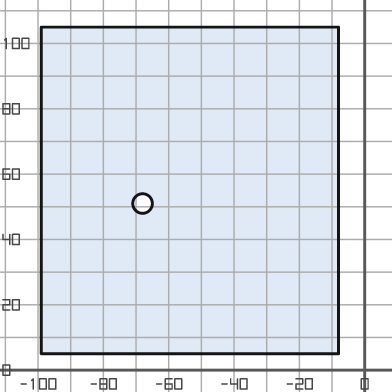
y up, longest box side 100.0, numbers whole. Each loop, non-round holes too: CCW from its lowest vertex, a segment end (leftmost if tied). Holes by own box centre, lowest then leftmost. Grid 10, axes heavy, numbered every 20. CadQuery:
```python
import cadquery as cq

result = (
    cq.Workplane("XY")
    .moveTo(-99.0, 5.0)
    .lineTo(-8.0, 5.0)
    .lineTo(-8.0, 105.0)
    .lineTo(-99.0, 105.0)
    .close()
    .moveTo(-68.0, 51.0)
    .circle(3.0)
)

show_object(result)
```